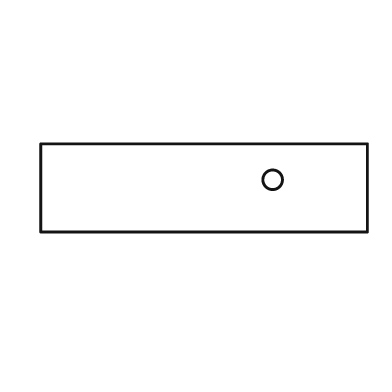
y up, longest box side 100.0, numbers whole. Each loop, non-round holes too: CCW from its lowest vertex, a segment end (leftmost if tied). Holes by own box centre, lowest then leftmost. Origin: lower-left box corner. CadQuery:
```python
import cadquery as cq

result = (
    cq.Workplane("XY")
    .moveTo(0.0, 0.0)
    .lineTo(100.0, 0.0)
    .lineTo(100.0, 27.0)
    .lineTo(0.0, 27.0)
    .close()
    .moveTo(71.0, 16.0)
    .circle(3.0)
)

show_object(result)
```